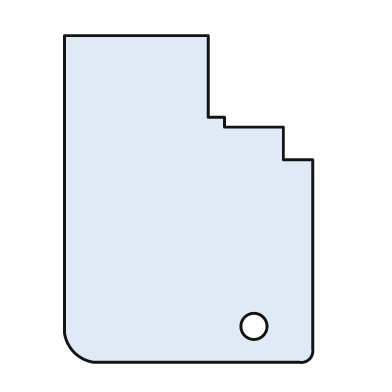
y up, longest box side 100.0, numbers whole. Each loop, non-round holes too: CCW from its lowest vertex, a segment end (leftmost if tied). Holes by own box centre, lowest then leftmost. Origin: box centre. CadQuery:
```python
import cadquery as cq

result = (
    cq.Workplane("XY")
    .moveTo(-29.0, -50.0)
    .lineTo(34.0, -50.0)
    .threePointArc((37.0, -49.0), (38.0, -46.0))
    .lineTo(38.0, 12.0)
    .lineTo(29.0, 12.0)
    .lineTo(29.0, 22.0)
    .lineTo(11.0, 22.0)
    .lineTo(11.0, 25.0)
    .lineTo(6.0, 25.0)
    .lineTo(6.0, 50.0)
    .lineTo(-38.0, 50.0)
    .lineTo(-38.0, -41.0)
    .threePointArc((-35.0, -47.0), (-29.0, -50.0))
    .close()
    .moveTo(20.0, -39.0)
    .circle(4.0)
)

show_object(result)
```